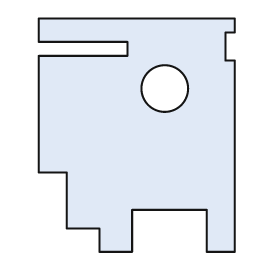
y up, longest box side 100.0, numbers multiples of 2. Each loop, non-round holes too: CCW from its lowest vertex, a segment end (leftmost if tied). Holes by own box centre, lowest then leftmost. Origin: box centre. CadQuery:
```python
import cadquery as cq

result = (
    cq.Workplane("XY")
    .moveTo(-16.0, -50.0)
    .lineTo(-2.0, -50.0)
    .lineTo(-2.0, -32.0)
    .lineTo(30.0, -32.0)
    .lineTo(30.0, -50.0)
    .lineTo(42.0, -50.0)
    .lineTo(42.0, 32.0)
    .lineTo(38.0, 32.0)
    .lineTo(38.0, 44.0)
    .lineTo(42.0, 44.0)
    .lineTo(42.0, 50.0)
    .lineTo(-42.0, 50.0)
    .lineTo(-42.0, 40.0)
    .lineTo(-4.0, 40.0)
    .lineTo(-4.0, 34.0)
    .lineTo(-42.0, 34.0)
    .lineTo(-42.0, -16.0)
    .lineTo(-30.0, -16.0)
    .lineTo(-30.0, -40.0)
    .lineTo(-16.0, -40.0)
    .close()
    .moveTo(12.0, 20.0)
    .circle(10.0)
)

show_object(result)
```